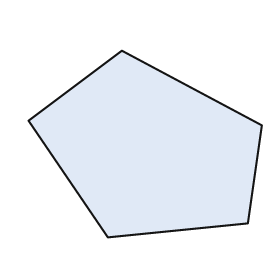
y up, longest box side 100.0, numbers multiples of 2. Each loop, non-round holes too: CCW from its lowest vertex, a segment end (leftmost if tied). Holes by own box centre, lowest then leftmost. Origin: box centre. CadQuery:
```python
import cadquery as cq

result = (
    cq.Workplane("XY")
    .moveTo(-16.0, -40.0)
    .lineTo(44.0, -34.0)
    .lineTo(50.0, 8.0)
    .lineTo(-10.0, 40.0)
    .lineTo(-50.0, 10.0)
    .close()
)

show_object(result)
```